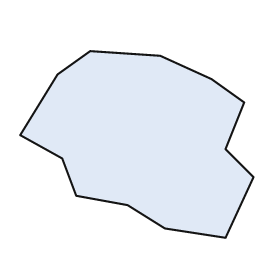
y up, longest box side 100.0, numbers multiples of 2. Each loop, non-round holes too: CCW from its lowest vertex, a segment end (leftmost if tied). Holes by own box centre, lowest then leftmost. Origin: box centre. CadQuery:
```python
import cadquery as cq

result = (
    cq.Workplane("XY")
    .moveTo(38.0, -40.0)
    .lineTo(50.0, -14.0)
    .lineTo(38.0, -2.0)
    .lineTo(46.0, 18.0)
    .lineTo(32.0, 28.0)
    .lineTo(10.0, 38.0)
    .lineTo(-20.0, 40.0)
    .lineTo(-34.0, 30.0)
    .lineTo(-50.0, 4.0)
    .lineTo(-32.0, -6.0)
    .lineTo(-26.0, -22.0)
    .lineTo(-4.0, -26.0)
    .lineTo(12.0, -36.0)
    .close()
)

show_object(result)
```